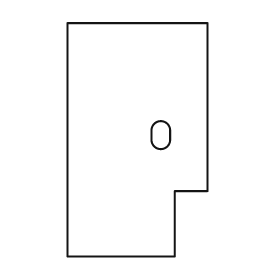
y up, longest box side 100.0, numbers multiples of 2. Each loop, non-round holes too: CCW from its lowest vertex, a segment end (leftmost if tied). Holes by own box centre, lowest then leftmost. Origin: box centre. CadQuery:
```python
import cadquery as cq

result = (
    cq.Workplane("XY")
    .moveTo(-30.0, -50.0)
    .lineTo(16.0, -50.0)
    .lineTo(16.0, -22.0)
    .lineTo(30.0, -22.0)
    .lineTo(30.0, 50.0)
    .lineTo(-30.0, 50.0)
    .close()
    .moveTo(6.0, 0.0)
    .threePointArc((10.0, -4.0), (14.0, 0.0))
    .lineTo(14.0, 4.0)
    .threePointArc((10.0, 8.0), (6.0, 4.0))
    .close()
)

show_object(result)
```